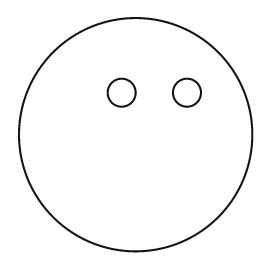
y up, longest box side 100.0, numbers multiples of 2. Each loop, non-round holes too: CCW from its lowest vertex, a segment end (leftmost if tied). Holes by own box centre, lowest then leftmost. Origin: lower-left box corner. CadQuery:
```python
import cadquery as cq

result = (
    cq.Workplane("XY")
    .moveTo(50.0, 50.0)
    .circle(50.0)
    .moveTo(44.0, 68.0)
    .circle(6.0)
    .moveTo(72.0, 68.0)
    .circle(6.0)
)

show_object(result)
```